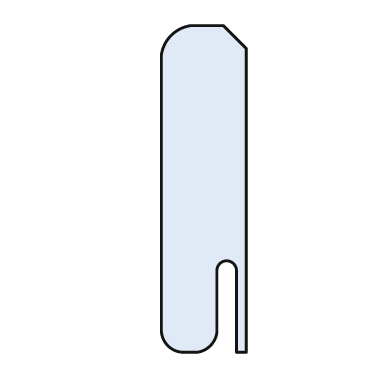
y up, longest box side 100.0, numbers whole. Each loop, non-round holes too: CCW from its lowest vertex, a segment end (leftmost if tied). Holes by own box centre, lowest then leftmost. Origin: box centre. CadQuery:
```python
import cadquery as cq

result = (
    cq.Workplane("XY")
    .moveTo(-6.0, -50.0)
    .lineTo(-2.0, -50.0)
    .threePointArc((2.0, -48.0), (4.0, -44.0))
    .lineTo(4.0, -25.0)
    .threePointArc((7.0, -22.0), (10.0, -25.0))
    .lineTo(10.0, -50.0)
    .lineTo(13.0, -50.0)
    .lineTo(13.0, 43.0)
    .lineTo(6.0, 50.0)
    .lineTo(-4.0, 50.0)
    .threePointArc((-10.0, 47.0), (-13.0, 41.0))
    .lineTo(-13.0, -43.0)
    .threePointArc((-11.0, -48.0), (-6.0, -50.0))
    .close()
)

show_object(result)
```